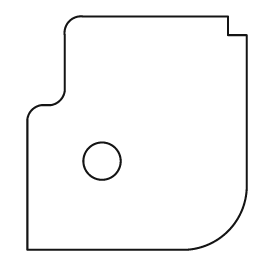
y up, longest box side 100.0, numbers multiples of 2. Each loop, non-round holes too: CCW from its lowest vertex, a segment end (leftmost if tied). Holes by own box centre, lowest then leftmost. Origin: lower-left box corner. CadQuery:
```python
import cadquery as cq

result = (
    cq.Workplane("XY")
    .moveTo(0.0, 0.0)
    .lineTo(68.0, 0.0)
    .threePointArc((86.0, 8.0), (94.0, 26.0))
    .lineTo(94.0, 92.0)
    .lineTo(86.0, 92.0)
    .lineTo(86.0, 100.0)
    .lineTo(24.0, 100.0)
    .threePointArc((18.0, 98.0), (16.0, 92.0))
    .lineTo(16.0, 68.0)
    .threePointArc((14.0, 64.0), (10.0, 62.0))
    .lineTo(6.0, 62.0)
    .threePointArc((2.0, 60.0), (0.0, 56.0))
    .close()
    .moveTo(32.0, 38.0)
    .circle(8.0)
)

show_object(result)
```